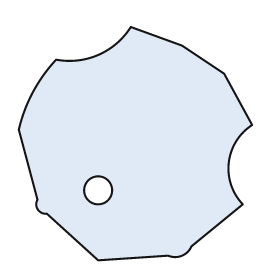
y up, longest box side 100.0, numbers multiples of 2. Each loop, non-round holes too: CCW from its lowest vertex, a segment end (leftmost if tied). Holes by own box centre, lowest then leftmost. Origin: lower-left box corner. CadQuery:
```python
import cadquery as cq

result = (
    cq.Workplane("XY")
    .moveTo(34.0, 0.0)
    .lineTo(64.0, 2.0)
    .threePointArc((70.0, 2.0), (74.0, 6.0))
    .lineTo(96.0, 24.0)
    .threePointArc((90.0, 42.0), (100.0, 58.0))
    .lineTo(88.0, 80.0)
    .lineTo(70.0, 92.0)
    .lineTo(48.0, 100.0)
    .threePointArc((34.0, 88.0), (16.0, 86.0))
    .threePointArc((6.0, 72.0), (0.0, 56.0))
    .lineTo(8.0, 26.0)
    .threePointArc((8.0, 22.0), (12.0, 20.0))
    .close()
    .moveTo(34.0, 30.0)
    .circle(6.0)
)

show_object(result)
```